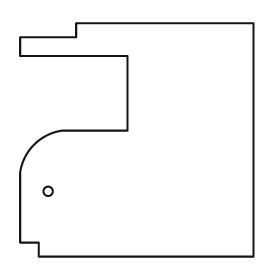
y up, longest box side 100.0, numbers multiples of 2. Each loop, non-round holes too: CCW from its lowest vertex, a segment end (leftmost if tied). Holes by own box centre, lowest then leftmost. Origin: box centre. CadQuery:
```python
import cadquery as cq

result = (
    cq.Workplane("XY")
    .moveTo(-42.0, -50.0)
    .lineTo(50.0, -50.0)
    .lineTo(50.0, 50.0)
    .lineTo(-26.0, 50.0)
    .lineTo(-26.0, 44.0)
    .lineTo(-50.0, 44.0)
    .lineTo(-50.0, 36.0)
    .lineTo(-4.0, 36.0)
    .lineTo(-4.0, 4.0)
    .lineTo(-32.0, 4.0)
    .threePointArc((-44.0, -2.0), (-50.0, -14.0))
    .lineTo(-50.0, -44.0)
    .lineTo(-42.0, -44.0)
    .close()
    .moveTo(-38.0, -22.0)
    .circle(2.0)
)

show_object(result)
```